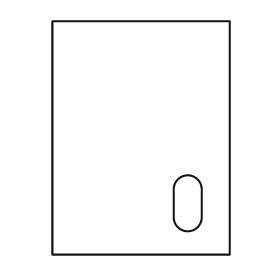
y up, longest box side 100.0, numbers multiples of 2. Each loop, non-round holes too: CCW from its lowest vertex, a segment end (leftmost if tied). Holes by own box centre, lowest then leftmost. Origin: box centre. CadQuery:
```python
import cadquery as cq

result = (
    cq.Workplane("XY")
    .moveTo(-38.0, -50.0)
    .lineTo(38.0, -50.0)
    .lineTo(38.0, 50.0)
    .lineTo(-38.0, 50.0)
    .close()
    .moveTo(14.0, -34.0)
    .threePointArc((20.0, -40.0), (26.0, -34.0))
    .lineTo(26.0, -22.0)
    .threePointArc((20.0, -16.0), (14.0, -22.0))
    .close()
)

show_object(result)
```